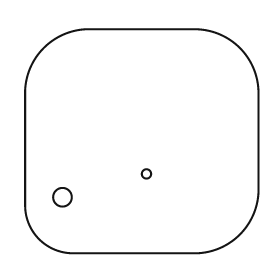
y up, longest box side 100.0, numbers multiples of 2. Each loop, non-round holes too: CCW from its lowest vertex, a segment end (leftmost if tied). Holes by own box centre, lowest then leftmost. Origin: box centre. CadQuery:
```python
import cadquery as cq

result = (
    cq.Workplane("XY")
    .moveTo(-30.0, -48.0)
    .lineTo(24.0, -48.0)
    .threePointArc((42.0, -40.0), (50.0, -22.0))
    .lineTo(50.0, 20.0)
    .threePointArc((42.0, 40.0), (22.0, 48.0))
    .lineTo(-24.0, 48.0)
    .threePointArc((-42.0, 40.0), (-50.0, 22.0))
    .lineTo(-50.0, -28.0)
    .threePointArc((-44.0, -42.0), (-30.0, -48.0))
    .close()
    .moveTo(-34.0, -24.0)
    .circle(4.0)
    .moveTo(2.0, -14.0)
    .circle(2.0)
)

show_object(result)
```